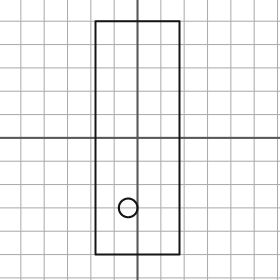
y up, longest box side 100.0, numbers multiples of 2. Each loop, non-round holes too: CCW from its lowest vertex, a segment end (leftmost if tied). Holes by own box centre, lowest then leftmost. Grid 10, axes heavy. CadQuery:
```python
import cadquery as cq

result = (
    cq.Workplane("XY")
    .moveTo(-18.0, -50.0)
    .lineTo(18.0, -50.0)
    .lineTo(18.0, 50.0)
    .lineTo(-18.0, 50.0)
    .close()
    .moveTo(-4.0, -30.0)
    .circle(4.0)
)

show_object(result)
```